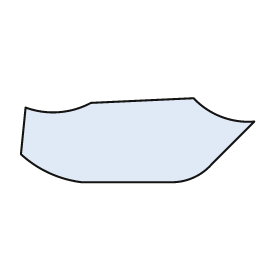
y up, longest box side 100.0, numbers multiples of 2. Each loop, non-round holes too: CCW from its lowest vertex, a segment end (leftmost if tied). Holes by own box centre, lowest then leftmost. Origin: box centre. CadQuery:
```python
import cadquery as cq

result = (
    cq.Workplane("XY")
    .moveTo(-24.0, -18.0)
    .lineTo(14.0, -18.0)
    .threePointArc((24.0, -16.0), (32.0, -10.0))
    .lineTo(50.0, 8.0)
    .threePointArc((36.0, 10.0), (24.0, 18.0))
    .lineTo(-20.0, 16.0)
    .threePointArc((-34.0, 12.0), (-48.0, 14.0))
    .lineTo(-50.0, -6.0)
    .threePointArc((-38.0, -14.0), (-24.0, -18.0))
    .close()
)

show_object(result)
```